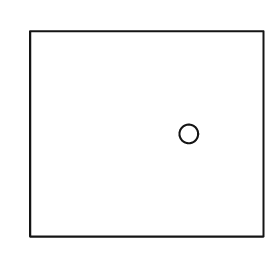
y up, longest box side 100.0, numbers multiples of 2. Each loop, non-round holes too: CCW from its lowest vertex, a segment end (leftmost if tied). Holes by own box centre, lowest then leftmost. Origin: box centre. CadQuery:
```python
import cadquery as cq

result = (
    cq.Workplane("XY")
    .moveTo(-50.0, -44.0)
    .lineTo(50.0, -44.0)
    .lineTo(50.0, 44.0)
    .lineTo(-50.0, 44.0)
    .close()
    .moveTo(18.0, 0.0)
    .circle(4.0)
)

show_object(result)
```